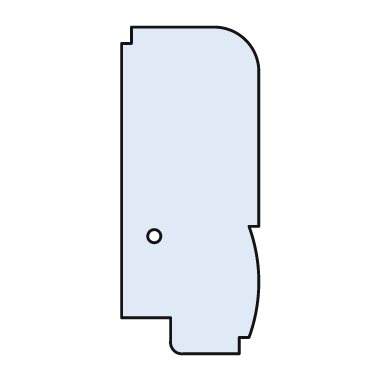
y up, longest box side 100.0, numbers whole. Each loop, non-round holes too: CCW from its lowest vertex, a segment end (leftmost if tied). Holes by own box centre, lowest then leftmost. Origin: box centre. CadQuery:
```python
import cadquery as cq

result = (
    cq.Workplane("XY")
    .moveTo(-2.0, -50.0)
    .lineTo(15.0, -50.0)
    .lineTo(15.0, -45.0)
    .lineTo(18.0, -45.0)
    .threePointArc((21.0, -28.0), (18.0, -11.0))
    .lineTo(21.0, -11.0)
    .lineTo(21.0, 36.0)
    .threePointArc((17.0, 46.0), (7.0, 50.0))
    .lineTo(-18.0, 50.0)
    .lineTo(-18.0, 45.0)
    .lineTo(-21.0, 45.0)
    .lineTo(-21.0, -39.0)
    .lineTo(-6.0, -39.0)
    .lineTo(-6.0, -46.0)
    .threePointArc((-5.0, -49.0), (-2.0, -50.0))
    .close()
    .moveTo(-11.0, -14.0)
    .circle(2.0)
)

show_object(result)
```